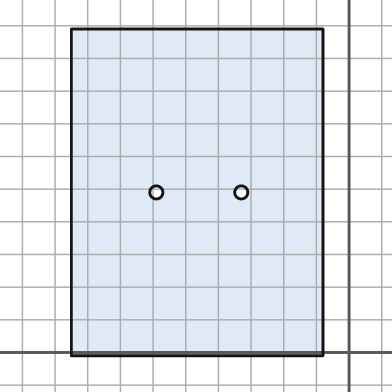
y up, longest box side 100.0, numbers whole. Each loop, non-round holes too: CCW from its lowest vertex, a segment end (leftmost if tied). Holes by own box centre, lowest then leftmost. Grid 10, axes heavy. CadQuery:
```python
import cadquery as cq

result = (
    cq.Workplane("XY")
    .moveTo(-85.0, -1.0)
    .lineTo(-8.0, -1.0)
    .lineTo(-8.0, 99.0)
    .lineTo(-85.0, 99.0)
    .close()
    .moveTo(-59.0, 49.0)
    .circle(2.0)
    .moveTo(-33.0, 49.0)
    .circle(2.0)
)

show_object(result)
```